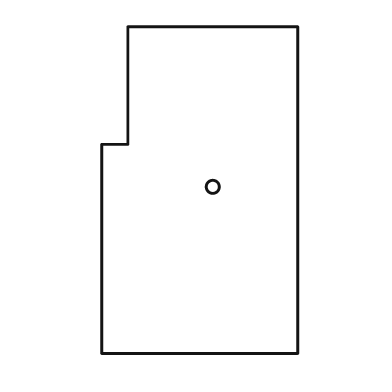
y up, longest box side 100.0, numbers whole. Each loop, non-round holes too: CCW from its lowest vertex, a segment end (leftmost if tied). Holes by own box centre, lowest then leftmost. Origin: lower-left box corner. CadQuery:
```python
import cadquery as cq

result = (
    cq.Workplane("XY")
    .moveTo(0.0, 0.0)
    .lineTo(60.0, 0.0)
    .lineTo(60.0, 100.0)
    .lineTo(8.0, 100.0)
    .lineTo(8.0, 64.0)
    .lineTo(0.0, 64.0)
    .close()
    .moveTo(34.0, 51.0)
    .circle(2.0)
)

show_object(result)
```